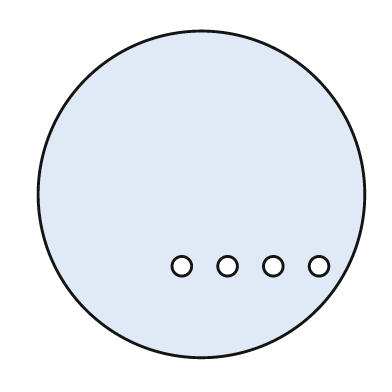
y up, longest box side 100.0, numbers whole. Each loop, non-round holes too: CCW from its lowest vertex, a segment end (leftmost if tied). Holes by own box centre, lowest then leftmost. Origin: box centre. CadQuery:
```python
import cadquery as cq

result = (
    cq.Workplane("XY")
    .moveTo(0.0, 0.0)
    .circle(50.0)
    .moveTo(-6.0, -22.0)
    .circle(3.0)
    .moveTo(8.0, -22.0)
    .circle(3.0)
    .moveTo(22.0, -22.0)
    .circle(3.0)
    .moveTo(36.0, -22.0)
    .circle(3.0)
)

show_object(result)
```